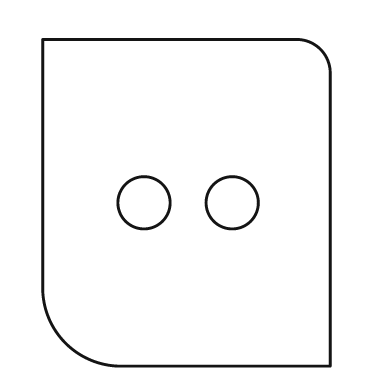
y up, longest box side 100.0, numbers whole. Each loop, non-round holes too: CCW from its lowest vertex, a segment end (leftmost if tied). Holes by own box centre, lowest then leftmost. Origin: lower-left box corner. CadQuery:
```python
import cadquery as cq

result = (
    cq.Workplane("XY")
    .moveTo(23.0, 0.0)
    .lineTo(88.0, 0.0)
    .lineTo(88.0, 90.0)
    .threePointArc((85.0, 97.0), (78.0, 100.0))
    .lineTo(0.0, 100.0)
    .lineTo(0.0, 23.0)
    .threePointArc((7.0, 7.0), (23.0, 0.0))
    .close()
    .moveTo(31.0, 50.0)
    .circle(8.0)
    .moveTo(58.0, 50.0)
    .circle(8.0)
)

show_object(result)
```